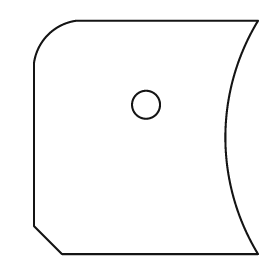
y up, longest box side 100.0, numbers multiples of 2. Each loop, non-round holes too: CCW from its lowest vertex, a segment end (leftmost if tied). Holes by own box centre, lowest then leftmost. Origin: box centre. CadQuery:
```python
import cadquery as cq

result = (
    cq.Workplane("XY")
    .moveTo(-36.0, -50.0)
    .lineTo(48.0, -50.0)
    .threePointArc((34.0, 0.0), (48.0, 50.0))
    .lineTo(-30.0, 50.0)
    .threePointArc((-42.0, 44.0), (-48.0, 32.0))
    .lineTo(-48.0, -38.0)
    .close()
    .moveTo(0.0, 14.0)
    .circle(6.0)
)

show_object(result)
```